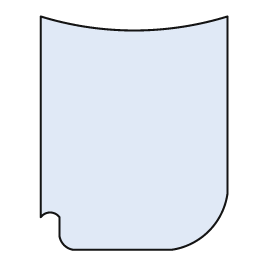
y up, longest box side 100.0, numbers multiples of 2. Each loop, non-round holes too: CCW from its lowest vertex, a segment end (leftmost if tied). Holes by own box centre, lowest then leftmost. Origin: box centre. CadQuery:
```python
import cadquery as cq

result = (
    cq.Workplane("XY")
    .moveTo(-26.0, -50.0)
    .lineTo(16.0, -50.0)
    .threePointArc((32.0, -42.0), (40.0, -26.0))
    .lineTo(40.0, 50.0)
    .threePointArc((0.0, 44.0), (-40.0, 50.0))
    .lineTo(-40.0, -36.0)
    .threePointArc((-36.0, -34.0), (-32.0, -36.0))
    .lineTo(-32.0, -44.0)
    .threePointArc((-30.0, -48.0), (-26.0, -50.0))
    .close()
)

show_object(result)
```